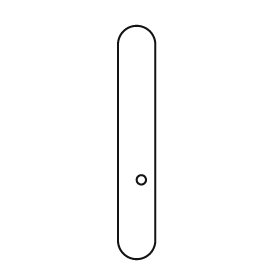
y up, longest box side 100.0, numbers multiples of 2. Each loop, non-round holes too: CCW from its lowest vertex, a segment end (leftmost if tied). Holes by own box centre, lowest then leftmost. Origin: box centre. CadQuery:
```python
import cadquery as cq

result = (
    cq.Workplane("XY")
    .moveTo(-8.0, -42.0)
    .threePointArc((0.0, -50.0), (8.0, -42.0))
    .lineTo(8.0, 42.0)
    .threePointArc((0.0, 50.0), (-8.0, 42.0))
    .close()
    .moveTo(2.0, -16.0)
    .circle(2.0)
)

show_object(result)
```